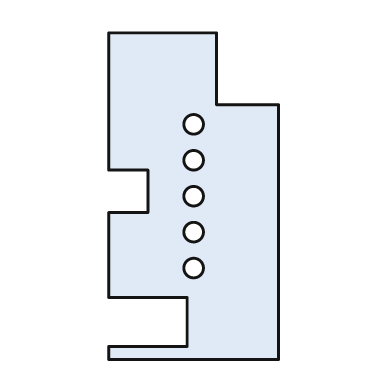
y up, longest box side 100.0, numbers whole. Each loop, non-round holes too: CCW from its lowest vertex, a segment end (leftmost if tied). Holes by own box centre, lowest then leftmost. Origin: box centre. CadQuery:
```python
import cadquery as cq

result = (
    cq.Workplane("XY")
    .moveTo(-26.0, -50.0)
    .lineTo(26.0, -50.0)
    .lineTo(26.0, 28.0)
    .lineTo(7.0, 28.0)
    .lineTo(7.0, 50.0)
    .lineTo(-26.0, 50.0)
    .lineTo(-26.0, 8.0)
    .lineTo(-14.0, 8.0)
    .lineTo(-14.0, -5.0)
    .lineTo(-26.0, -5.0)
    .lineTo(-26.0, -31.0)
    .lineTo(-2.0, -31.0)
    .lineTo(-2.0, -46.0)
    .lineTo(-26.0, -46.0)
    .close()
    .moveTo(0.0, -22.0)
    .circle(3.0)
    .moveTo(0.0, -11.0)
    .circle(3.0)
    .moveTo(0.0, 0.0)
    .circle(3.0)
    .moveTo(0.0, 11.0)
    .circle(3.0)
    .moveTo(0.0, 22.0)
    .circle(3.0)
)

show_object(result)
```